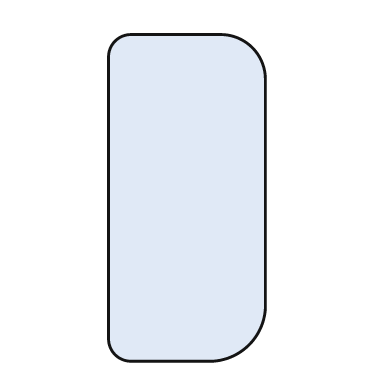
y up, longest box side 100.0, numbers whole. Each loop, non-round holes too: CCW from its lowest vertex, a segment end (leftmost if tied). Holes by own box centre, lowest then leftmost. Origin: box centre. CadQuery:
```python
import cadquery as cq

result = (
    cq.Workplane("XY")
    .moveTo(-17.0, -50.0)
    .lineTo(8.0, -50.0)
    .threePointArc((19.0, -45.0), (24.0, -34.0))
    .lineTo(24.0, 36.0)
    .threePointArc((20.0, 46.0), (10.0, 50.0))
    .lineTo(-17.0, 50.0)
    .threePointArc((-22.0, 48.0), (-24.0, 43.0))
    .lineTo(-24.0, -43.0)
    .threePointArc((-22.0, -48.0), (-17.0, -50.0))
    .close()
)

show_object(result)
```